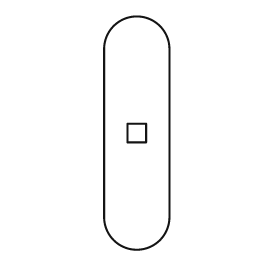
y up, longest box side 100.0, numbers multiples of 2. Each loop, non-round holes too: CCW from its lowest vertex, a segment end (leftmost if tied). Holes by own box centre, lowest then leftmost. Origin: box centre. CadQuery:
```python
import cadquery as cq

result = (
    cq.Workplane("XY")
    .moveTo(-14.0, -36.0)
    .threePointArc((0.0, -50.0), (14.0, -36.0))
    .lineTo(14.0, 36.0)
    .threePointArc((0.0, 50.0), (-14.0, 36.0))
    .close()
    .moveTo(-4.0, -4.0)
    .lineTo(4.0, -4.0)
    .lineTo(4.0, 4.0)
    .lineTo(-4.0, 4.0)
    .close()
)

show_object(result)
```